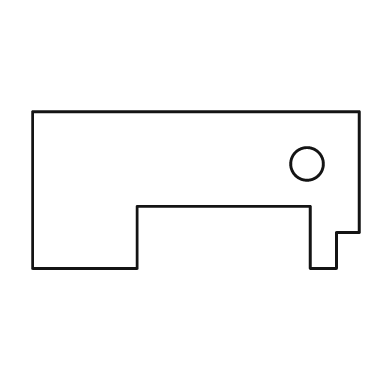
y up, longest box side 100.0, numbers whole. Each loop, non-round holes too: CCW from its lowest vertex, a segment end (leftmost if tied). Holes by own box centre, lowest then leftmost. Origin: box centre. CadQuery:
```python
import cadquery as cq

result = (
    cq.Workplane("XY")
    .moveTo(-50.0, -24.0)
    .lineTo(-18.0, -24.0)
    .lineTo(-18.0, -5.0)
    .lineTo(35.0, -5.0)
    .lineTo(35.0, -24.0)
    .lineTo(43.0, -24.0)
    .lineTo(43.0, -13.0)
    .lineTo(50.0, -13.0)
    .lineTo(50.0, 24.0)
    .lineTo(-50.0, 24.0)
    .close()
    .moveTo(34.0, 8.0)
    .circle(5.0)
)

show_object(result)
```